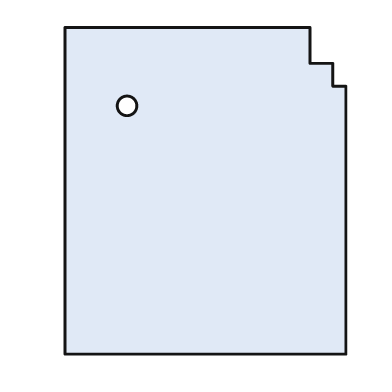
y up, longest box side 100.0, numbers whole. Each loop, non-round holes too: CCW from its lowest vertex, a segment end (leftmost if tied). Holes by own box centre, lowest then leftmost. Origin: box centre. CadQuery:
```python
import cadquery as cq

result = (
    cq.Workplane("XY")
    .moveTo(-43.0, -50.0)
    .lineTo(43.0, -50.0)
    .lineTo(43.0, 32.0)
    .lineTo(39.0, 32.0)
    .lineTo(39.0, 39.0)
    .lineTo(32.0, 39.0)
    .lineTo(32.0, 50.0)
    .lineTo(-43.0, 50.0)
    .close()
    .moveTo(-24.0, 26.0)
    .circle(3.0)
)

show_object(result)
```